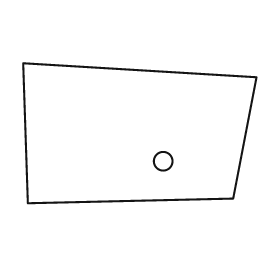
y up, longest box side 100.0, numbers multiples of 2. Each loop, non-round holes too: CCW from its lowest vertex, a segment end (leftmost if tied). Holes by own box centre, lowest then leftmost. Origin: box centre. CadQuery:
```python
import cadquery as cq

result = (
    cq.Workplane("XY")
    .moveTo(-48.0, -30.0)
    .lineTo(40.0, -28.0)
    .lineTo(50.0, 24.0)
    .lineTo(-50.0, 30.0)
    .close()
    .moveTo(10.0, -12.0)
    .circle(4.0)
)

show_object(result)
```